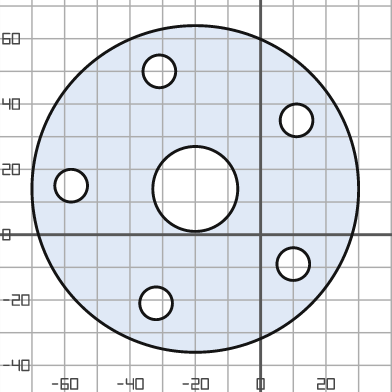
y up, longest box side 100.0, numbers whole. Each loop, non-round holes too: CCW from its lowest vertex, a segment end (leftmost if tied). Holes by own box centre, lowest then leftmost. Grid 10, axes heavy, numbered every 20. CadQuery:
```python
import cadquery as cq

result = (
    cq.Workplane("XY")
    .moveTo(-20.0, 14.0)
    .circle(50.0)
    .moveTo(-32.0, -21.0)
    .circle(5.0)
    .moveTo(10.0, -9.0)
    .circle(5.0)
    .moveTo(-20.0, 14.0)
    .circle(13.0)
    .moveTo(-58.0, 15.0)
    .circle(5.0)
    .moveTo(11.0, 35.0)
    .circle(5.0)
    .moveTo(-31.0, 50.0)
    .circle(5.0)
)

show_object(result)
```